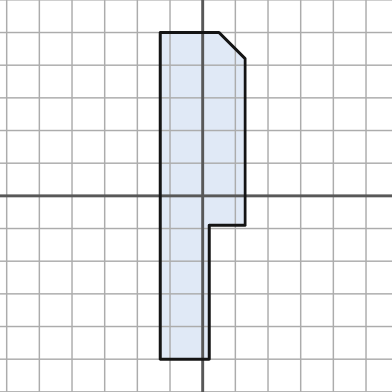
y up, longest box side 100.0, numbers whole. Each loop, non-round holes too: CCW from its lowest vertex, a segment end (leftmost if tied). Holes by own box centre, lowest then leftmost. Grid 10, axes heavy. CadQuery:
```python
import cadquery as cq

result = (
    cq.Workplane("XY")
    .moveTo(-13.0, -50.0)
    .lineTo(2.0, -50.0)
    .lineTo(2.0, -9.0)
    .lineTo(13.0, -9.0)
    .lineTo(13.0, 42.0)
    .lineTo(5.0, 50.0)
    .lineTo(-13.0, 50.0)
    .close()
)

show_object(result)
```